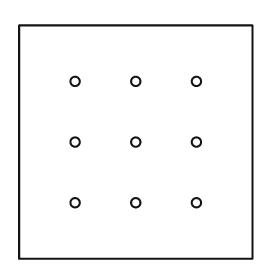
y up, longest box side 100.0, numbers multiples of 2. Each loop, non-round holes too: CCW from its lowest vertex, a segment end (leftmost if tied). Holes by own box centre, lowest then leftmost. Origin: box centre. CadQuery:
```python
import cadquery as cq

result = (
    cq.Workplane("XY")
    .moveTo(-50.0, -50.0)
    .lineTo(50.0, -50.0)
    .lineTo(50.0, 50.0)
    .lineTo(-50.0, 50.0)
    .close()
    .moveTo(-26.0, -26.0)
    .circle(2.0)
    .moveTo(0.0, -26.0)
    .circle(2.0)
    .moveTo(26.0, -26.0)
    .circle(2.0)
    .moveTo(-26.0, 0.0)
    .circle(2.0)
    .moveTo(0.0, 0.0)
    .circle(2.0)
    .moveTo(26.0, 0.0)
    .circle(2.0)
    .moveTo(-26.0, 26.0)
    .circle(2.0)
    .moveTo(0.0, 26.0)
    .circle(2.0)
    .moveTo(26.0, 26.0)
    .circle(2.0)
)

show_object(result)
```